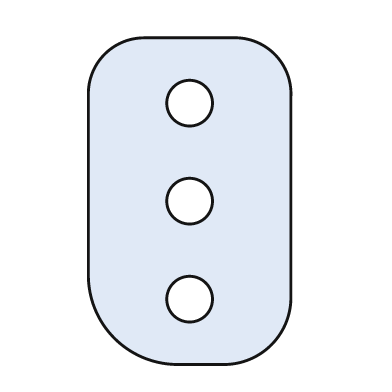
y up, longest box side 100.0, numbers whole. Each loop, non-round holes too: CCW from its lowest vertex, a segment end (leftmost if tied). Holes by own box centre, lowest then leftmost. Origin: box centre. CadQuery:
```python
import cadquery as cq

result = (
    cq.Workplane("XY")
    .moveTo(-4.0, -50.0)
    .lineTo(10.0, -50.0)
    .threePointArc((25.0, -44.0), (31.0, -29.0))
    .lineTo(31.0, 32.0)
    .threePointArc((26.0, 45.0), (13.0, 50.0))
    .lineTo(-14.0, 50.0)
    .threePointArc((-26.0, 45.0), (-31.0, 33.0))
    .lineTo(-31.0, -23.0)
    .threePointArc((-23.0, -42.0), (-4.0, -50.0))
    .close()
    .moveTo(0.0, -30.0)
    .circle(7.0)
    .moveTo(0.0, 0.0)
    .circle(7.0)
    .moveTo(0.0, 30.0)
    .circle(7.0)
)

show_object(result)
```